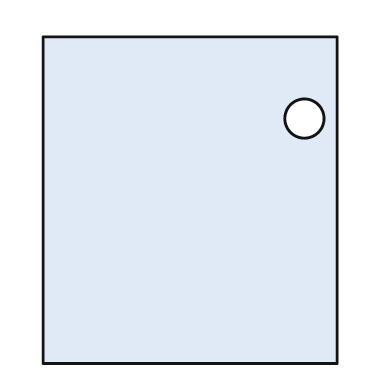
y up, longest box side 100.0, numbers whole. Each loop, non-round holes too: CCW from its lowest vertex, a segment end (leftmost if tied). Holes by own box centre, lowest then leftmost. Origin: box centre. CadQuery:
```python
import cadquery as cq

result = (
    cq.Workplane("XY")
    .moveTo(-45.0, -50.0)
    .lineTo(45.0, -50.0)
    .lineTo(45.0, 50.0)
    .lineTo(-45.0, 50.0)
    .close()
    .moveTo(35.0, 25.0)
    .circle(6.0)
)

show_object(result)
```